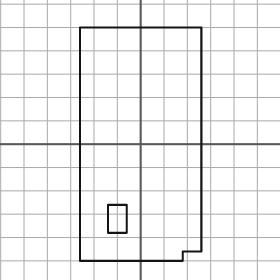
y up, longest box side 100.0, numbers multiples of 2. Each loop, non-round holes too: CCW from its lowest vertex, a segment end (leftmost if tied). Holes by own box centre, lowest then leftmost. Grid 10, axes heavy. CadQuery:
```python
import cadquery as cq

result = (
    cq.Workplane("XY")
    .moveTo(-26.0, -50.0)
    .lineTo(18.0, -50.0)
    .lineTo(18.0, -46.0)
    .lineTo(26.0, -46.0)
    .lineTo(26.0, 50.0)
    .lineTo(-26.0, 50.0)
    .close()
    .moveTo(-14.0, -38.0)
    .lineTo(-6.0, -38.0)
    .lineTo(-6.0, -26.0)
    .lineTo(-14.0, -26.0)
    .close()
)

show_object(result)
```